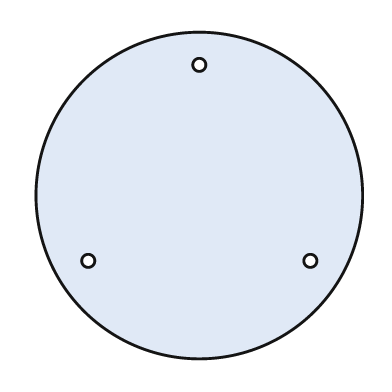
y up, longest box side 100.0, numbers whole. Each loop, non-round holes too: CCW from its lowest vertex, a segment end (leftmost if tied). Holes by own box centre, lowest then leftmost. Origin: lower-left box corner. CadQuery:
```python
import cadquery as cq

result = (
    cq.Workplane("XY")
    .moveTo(50.0, 50.0)
    .circle(50.0)
    .moveTo(16.0, 30.0)
    .circle(2.0)
    .moveTo(84.0, 30.0)
    .circle(2.0)
    .moveTo(50.0, 90.0)
    .circle(2.0)
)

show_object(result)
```